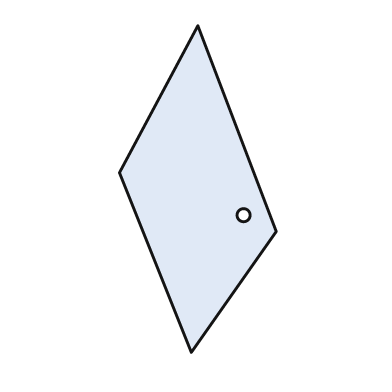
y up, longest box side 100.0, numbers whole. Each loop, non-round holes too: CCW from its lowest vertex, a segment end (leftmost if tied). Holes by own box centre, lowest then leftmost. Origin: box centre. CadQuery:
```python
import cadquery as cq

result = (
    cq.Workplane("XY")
    .moveTo(-2.0, -50.0)
    .lineTo(24.0, -13.0)
    .lineTo(0.0, 50.0)
    .lineTo(-24.0, 5.0)
    .close()
    .moveTo(14.0, -8.0)
    .circle(2.0)
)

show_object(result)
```